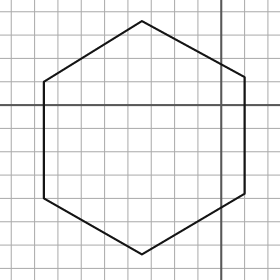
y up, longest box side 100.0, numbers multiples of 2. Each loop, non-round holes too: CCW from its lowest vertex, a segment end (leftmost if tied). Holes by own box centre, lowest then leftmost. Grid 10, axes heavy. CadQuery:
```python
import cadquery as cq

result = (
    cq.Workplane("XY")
    .moveTo(-34.0, -64.0)
    .lineTo(10.0, -38.0)
    .lineTo(10.0, 12.0)
    .lineTo(-34.0, 36.0)
    .lineTo(-76.0, 10.0)
    .lineTo(-76.0, -40.0)
    .close()
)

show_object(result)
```